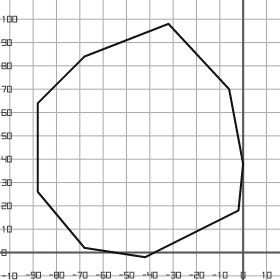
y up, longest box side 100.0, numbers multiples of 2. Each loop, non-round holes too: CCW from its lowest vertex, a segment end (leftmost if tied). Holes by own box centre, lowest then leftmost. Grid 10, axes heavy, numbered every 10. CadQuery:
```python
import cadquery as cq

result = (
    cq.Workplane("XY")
    .moveTo(-42.0, -2.0)
    .lineTo(-2.0, 18.0)
    .lineTo(0.0, 38.0)
    .lineTo(-6.0, 70.0)
    .lineTo(-32.0, 98.0)
    .lineTo(-68.0, 84.0)
    .lineTo(-88.0, 64.0)
    .lineTo(-88.0, 26.0)
    .lineTo(-68.0, 2.0)
    .close()
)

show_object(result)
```